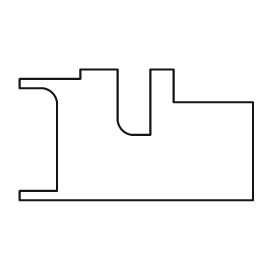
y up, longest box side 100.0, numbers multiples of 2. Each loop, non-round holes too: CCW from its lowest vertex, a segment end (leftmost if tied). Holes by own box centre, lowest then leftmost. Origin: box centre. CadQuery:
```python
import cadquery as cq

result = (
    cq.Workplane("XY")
    .moveTo(-50.0, -28.0)
    .lineTo(50.0, -28.0)
    .lineTo(50.0, 14.0)
    .lineTo(16.0, 14.0)
    .lineTo(16.0, 28.0)
    .lineTo(6.0, 28.0)
    .lineTo(6.0, 0.0)
    .lineTo(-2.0, 0.0)
    .threePointArc((-6.0, 2.0), (-8.0, 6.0))
    .lineTo(-8.0, 28.0)
    .lineTo(-24.0, 28.0)
    .lineTo(-24.0, 24.0)
    .lineTo(-50.0, 24.0)
    .lineTo(-50.0, 20.0)
    .lineTo(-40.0, 20.0)
    .threePointArc((-36.0, 18.0), (-34.0, 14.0))
    .lineTo(-34.0, -24.0)
    .lineTo(-50.0, -24.0)
    .close()
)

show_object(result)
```